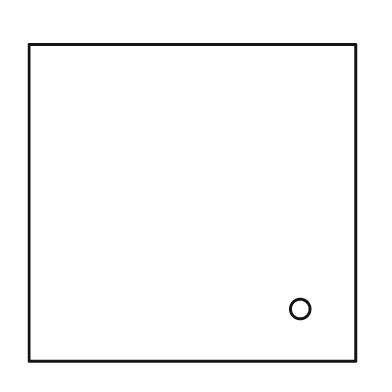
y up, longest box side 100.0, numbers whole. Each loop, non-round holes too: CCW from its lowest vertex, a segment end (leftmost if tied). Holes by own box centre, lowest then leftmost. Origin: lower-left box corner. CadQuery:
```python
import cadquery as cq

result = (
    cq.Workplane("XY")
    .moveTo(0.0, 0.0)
    .lineTo(100.0, 0.0)
    .lineTo(100.0, 97.0)
    .lineTo(0.0, 97.0)
    .close()
    .moveTo(83.0, 16.0)
    .circle(3.0)
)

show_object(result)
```